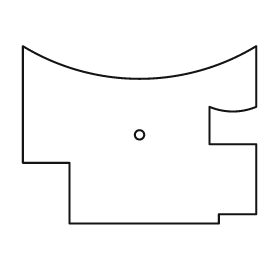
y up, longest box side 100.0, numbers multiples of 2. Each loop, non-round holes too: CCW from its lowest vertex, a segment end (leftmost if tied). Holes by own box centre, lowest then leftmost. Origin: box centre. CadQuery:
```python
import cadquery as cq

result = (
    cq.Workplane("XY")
    .moveTo(-30.0, -38.0)
    .lineTo(34.0, -38.0)
    .lineTo(34.0, -34.0)
    .lineTo(50.0, -34.0)
    .lineTo(50.0, -4.0)
    .lineTo(30.0, -4.0)
    .lineTo(30.0, 12.0)
    .threePointArc((40.0, 10.0), (50.0, 12.0))
    .lineTo(50.0, 38.0)
    .threePointArc((0.0, 24.0), (-50.0, 38.0))
    .lineTo(-50.0, -12.0)
    .lineTo(-30.0, -12.0)
    .close()
    .moveTo(0.0, 0.0)
    .circle(2.0)
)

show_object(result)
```